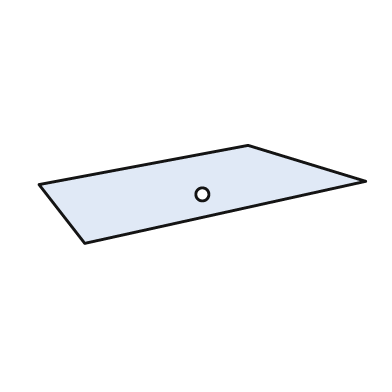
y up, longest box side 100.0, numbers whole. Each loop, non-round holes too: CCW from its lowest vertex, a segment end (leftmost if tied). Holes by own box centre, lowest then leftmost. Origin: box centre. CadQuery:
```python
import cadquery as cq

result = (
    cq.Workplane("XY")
    .moveTo(-36.0, -15.0)
    .lineTo(50.0, 4.0)
    .lineTo(14.0, 15.0)
    .lineTo(-50.0, 3.0)
    .close()
    .moveTo(0.0, 0.0)
    .circle(2.0)
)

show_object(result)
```